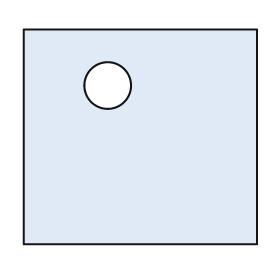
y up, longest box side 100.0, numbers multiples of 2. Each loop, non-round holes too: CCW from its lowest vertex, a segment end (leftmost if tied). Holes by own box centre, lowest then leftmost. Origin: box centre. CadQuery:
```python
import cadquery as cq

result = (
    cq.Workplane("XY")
    .moveTo(-50.0, -46.0)
    .lineTo(50.0, -46.0)
    .lineTo(50.0, 46.0)
    .lineTo(-50.0, 46.0)
    .close()
    .moveTo(-14.0, 22.0)
    .circle(10.0)
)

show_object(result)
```